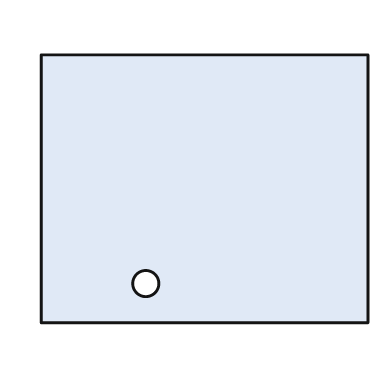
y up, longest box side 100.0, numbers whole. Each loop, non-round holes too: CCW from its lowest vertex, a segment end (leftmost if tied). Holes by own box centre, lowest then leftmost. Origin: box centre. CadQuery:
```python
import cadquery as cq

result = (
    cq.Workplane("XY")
    .moveTo(-50.0, -41.0)
    .lineTo(50.0, -41.0)
    .lineTo(50.0, 41.0)
    .lineTo(-50.0, 41.0)
    .close()
    .moveTo(-18.0, -29.0)
    .circle(4.0)
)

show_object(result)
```